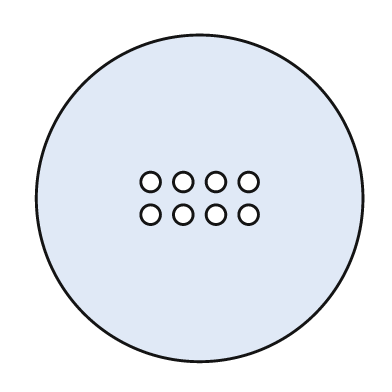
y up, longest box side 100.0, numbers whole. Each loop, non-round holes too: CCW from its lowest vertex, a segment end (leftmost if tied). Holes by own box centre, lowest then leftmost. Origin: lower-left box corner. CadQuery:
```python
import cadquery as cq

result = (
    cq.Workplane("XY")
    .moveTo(50.0, 50.0)
    .circle(50.0)
    .moveTo(35.0, 45.0)
    .circle(3.0)
    .moveTo(45.0, 45.0)
    .circle(3.0)
    .moveTo(55.0, 45.0)
    .circle(3.0)
    .moveTo(65.0, 45.0)
    .circle(3.0)
    .moveTo(35.0, 55.0)
    .circle(3.0)
    .moveTo(45.0, 55.0)
    .circle(3.0)
    .moveTo(55.0, 55.0)
    .circle(3.0)
    .moveTo(65.0, 55.0)
    .circle(3.0)
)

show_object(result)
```